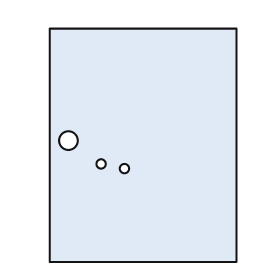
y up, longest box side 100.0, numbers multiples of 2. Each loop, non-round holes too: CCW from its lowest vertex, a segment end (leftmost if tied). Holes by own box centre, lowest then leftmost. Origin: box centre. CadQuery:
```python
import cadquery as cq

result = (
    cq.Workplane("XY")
    .moveTo(-40.0, -50.0)
    .lineTo(40.0, -50.0)
    .lineTo(40.0, 50.0)
    .lineTo(-40.0, 50.0)
    .close()
    .moveTo(-8.0, -10.0)
    .circle(2.0)
    .moveTo(-18.0, -8.0)
    .circle(2.0)
    .moveTo(-32.0, 2.0)
    .circle(4.0)
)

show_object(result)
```